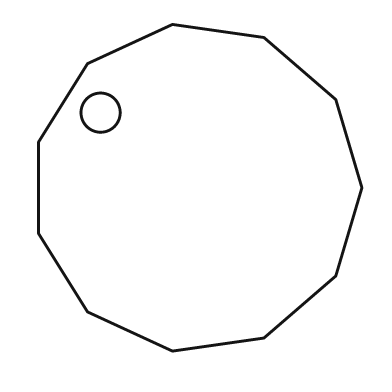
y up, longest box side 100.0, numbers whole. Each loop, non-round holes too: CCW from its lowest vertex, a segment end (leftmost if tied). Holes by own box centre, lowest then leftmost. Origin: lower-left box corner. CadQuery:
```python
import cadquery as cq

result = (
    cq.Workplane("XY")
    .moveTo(41.0, 0.0)
    .lineTo(69.0, 4.0)
    .lineTo(91.0, 23.0)
    .lineTo(99.0, 50.0)
    .lineTo(91.0, 77.0)
    .lineTo(69.0, 96.0)
    .lineTo(41.0, 100.0)
    .lineTo(15.0, 88.0)
    .lineTo(0.0, 64.0)
    .lineTo(0.0, 36.0)
    .lineTo(15.0, 12.0)
    .close()
    .moveTo(19.0, 73.0)
    .circle(6.0)
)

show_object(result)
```